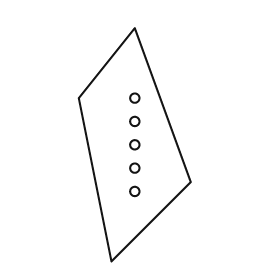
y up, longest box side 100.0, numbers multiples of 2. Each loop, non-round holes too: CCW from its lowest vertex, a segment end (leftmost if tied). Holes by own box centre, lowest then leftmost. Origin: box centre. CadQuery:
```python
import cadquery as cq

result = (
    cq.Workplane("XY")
    .moveTo(-10.0, -50.0)
    .lineTo(24.0, -16.0)
    .lineTo(0.0, 50.0)
    .lineTo(-24.0, 20.0)
    .close()
    .moveTo(0.0, -20.0)
    .circle(2.0)
    .moveTo(0.0, -10.0)
    .circle(2.0)
    .moveTo(0.0, 0.0)
    .circle(2.0)
    .moveTo(0.0, 10.0)
    .circle(2.0)
    .moveTo(0.0, 20.0)
    .circle(2.0)
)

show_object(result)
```